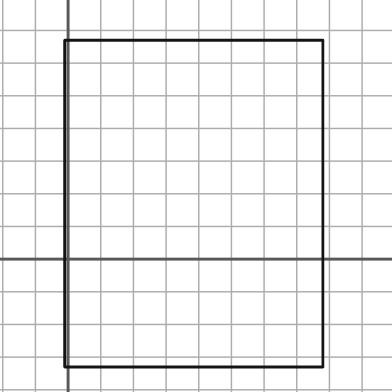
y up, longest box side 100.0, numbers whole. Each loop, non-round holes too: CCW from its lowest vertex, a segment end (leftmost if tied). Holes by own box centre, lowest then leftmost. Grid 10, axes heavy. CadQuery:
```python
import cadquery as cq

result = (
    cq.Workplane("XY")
    .moveTo(-1.0, -33.0)
    .lineTo(78.0, -33.0)
    .lineTo(78.0, 67.0)
    .lineTo(-1.0, 67.0)
    .close()
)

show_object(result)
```